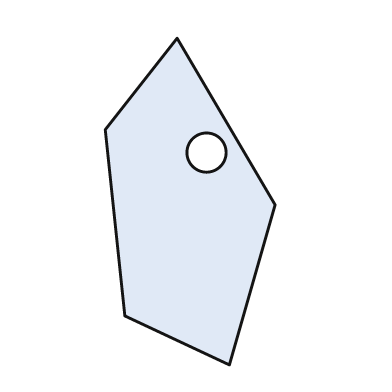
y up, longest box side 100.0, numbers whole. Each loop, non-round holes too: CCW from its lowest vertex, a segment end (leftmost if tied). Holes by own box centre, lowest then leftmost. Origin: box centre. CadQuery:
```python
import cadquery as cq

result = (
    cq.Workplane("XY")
    .moveTo(12.0, -50.0)
    .lineTo(26.0, -1.0)
    .lineTo(-4.0, 50.0)
    .lineTo(-26.0, 22.0)
    .lineTo(-20.0, -35.0)
    .close()
    .moveTo(5.0, 15.0)
    .circle(6.0)
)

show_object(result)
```